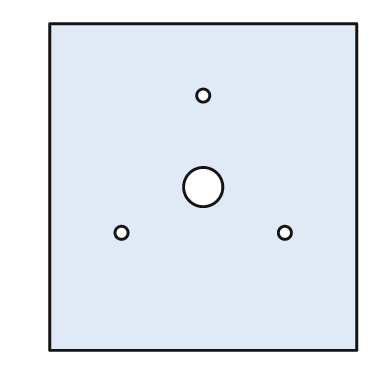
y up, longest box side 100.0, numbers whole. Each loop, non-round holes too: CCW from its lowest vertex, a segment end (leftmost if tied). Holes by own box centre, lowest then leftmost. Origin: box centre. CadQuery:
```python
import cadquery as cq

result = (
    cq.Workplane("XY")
    .moveTo(-47.0, -50.0)
    .lineTo(47.0, -50.0)
    .lineTo(47.0, 50.0)
    .lineTo(-47.0, 50.0)
    .close()
    .moveTo(-25.0, -14.0)
    .circle(2.0)
    .moveTo(25.0, -14.0)
    .circle(2.0)
    .moveTo(0.0, 0.0)
    .circle(6.0)
    .moveTo(0.0, 28.0)
    .circle(2.0)
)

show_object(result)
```